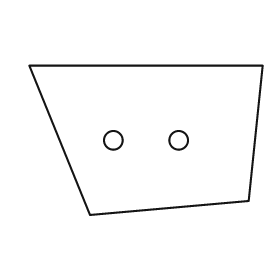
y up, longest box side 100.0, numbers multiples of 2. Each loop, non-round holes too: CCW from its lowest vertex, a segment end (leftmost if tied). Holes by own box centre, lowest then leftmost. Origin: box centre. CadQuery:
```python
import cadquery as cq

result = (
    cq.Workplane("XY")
    .moveTo(-24.0, -32.0)
    .lineTo(44.0, -26.0)
    .lineTo(50.0, 32.0)
    .lineTo(-50.0, 32.0)
    .close()
    .moveTo(-14.0, 0.0)
    .circle(4.0)
    .moveTo(14.0, 0.0)
    .circle(4.0)
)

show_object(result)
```